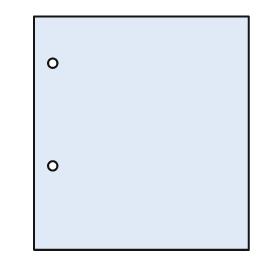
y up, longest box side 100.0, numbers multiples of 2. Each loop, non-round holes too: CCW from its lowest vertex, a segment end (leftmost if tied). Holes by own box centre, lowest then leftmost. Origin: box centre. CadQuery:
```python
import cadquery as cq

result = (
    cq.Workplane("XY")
    .moveTo(-46.0, -50.0)
    .lineTo(46.0, -50.0)
    .lineTo(46.0, 50.0)
    .lineTo(-46.0, 50.0)
    .close()
    .moveTo(-38.0, -14.0)
    .circle(2.0)
    .moveTo(-38.0, 30.0)
    .circle(2.0)
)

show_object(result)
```